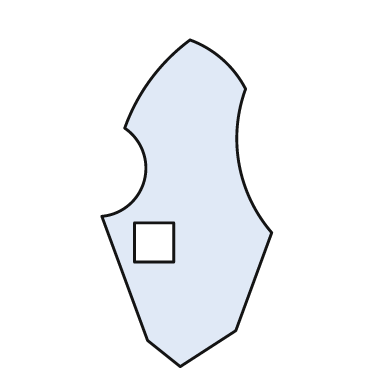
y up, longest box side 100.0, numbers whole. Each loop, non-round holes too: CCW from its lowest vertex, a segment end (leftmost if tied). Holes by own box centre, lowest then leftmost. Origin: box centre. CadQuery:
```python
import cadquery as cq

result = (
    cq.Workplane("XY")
    .moveTo(-2.0, -50.0)
    .lineTo(15.0, -39.0)
    .lineTo(26.0, -9.0)
    .threePointArc((16.0, 12.0), (18.0, 35.0))
    .threePointArc((11.0, 44.0), (1.0, 50.0))
    .threePointArc((-11.0, 38.0), (-19.0, 23.0))
    .threePointArc((-13.0, 7.0), (-26.0, -4.0))
    .lineTo(-12.0, -42.0)
    .close()
    .moveTo(-16.0, -18.0)
    .lineTo(-4.0, -18.0)
    .lineTo(-4.0, -6.0)
    .lineTo(-16.0, -6.0)
    .close()
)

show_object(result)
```